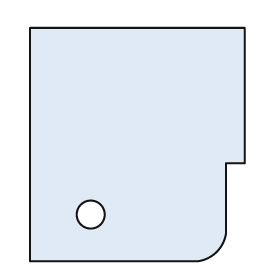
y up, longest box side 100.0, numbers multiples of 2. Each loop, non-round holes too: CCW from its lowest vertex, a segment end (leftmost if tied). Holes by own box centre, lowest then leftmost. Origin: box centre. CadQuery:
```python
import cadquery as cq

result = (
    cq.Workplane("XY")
    .moveTo(-46.0, -50.0)
    .lineTo(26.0, -50.0)
    .threePointArc((34.0, -46.0), (38.0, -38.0))
    .lineTo(38.0, -8.0)
    .lineTo(46.0, -8.0)
    .lineTo(46.0, 50.0)
    .lineTo(-46.0, 50.0)
    .close()
    .moveTo(-20.0, -30.0)
    .circle(6.0)
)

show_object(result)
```